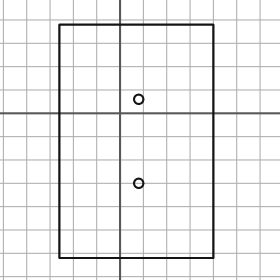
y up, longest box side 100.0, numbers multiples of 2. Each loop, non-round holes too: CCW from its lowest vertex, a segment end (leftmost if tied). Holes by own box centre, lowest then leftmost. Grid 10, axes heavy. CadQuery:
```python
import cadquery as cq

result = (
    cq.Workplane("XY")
    .moveTo(-26.0, -62.0)
    .lineTo(40.0, -62.0)
    .lineTo(40.0, 38.0)
    .lineTo(-26.0, 38.0)
    .close()
    .moveTo(8.0, -30.0)
    .circle(2.0)
    .moveTo(8.0, 6.0)
    .circle(2.0)
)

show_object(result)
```